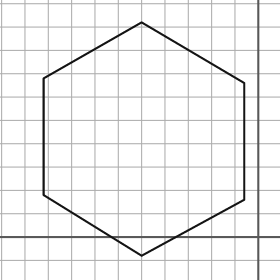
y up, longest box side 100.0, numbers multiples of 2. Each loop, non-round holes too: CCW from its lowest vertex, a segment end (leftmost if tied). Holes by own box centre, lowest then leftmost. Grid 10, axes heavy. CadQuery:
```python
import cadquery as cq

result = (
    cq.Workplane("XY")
    .moveTo(-50.0, -8.0)
    .lineTo(-6.0, 16.0)
    .lineTo(-6.0, 66.0)
    .lineTo(-50.0, 92.0)
    .lineTo(-92.0, 68.0)
    .lineTo(-92.0, 18.0)
    .close()
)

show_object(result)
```